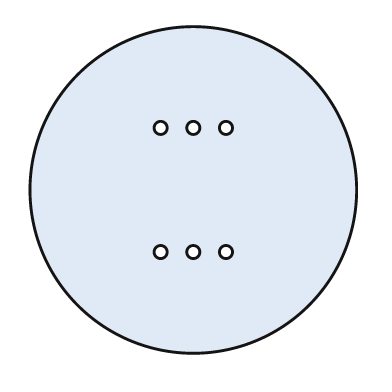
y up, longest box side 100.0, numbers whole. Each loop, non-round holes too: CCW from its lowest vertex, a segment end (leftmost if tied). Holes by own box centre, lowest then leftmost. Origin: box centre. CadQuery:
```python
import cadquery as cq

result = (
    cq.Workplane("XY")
    .moveTo(0.0, 0.0)
    .circle(50.0)
    .moveTo(-10.0, -19.0)
    .circle(2.0)
    .moveTo(0.0, -19.0)
    .circle(2.0)
    .moveTo(10.0, -19.0)
    .circle(2.0)
    .moveTo(-10.0, 19.0)
    .circle(2.0)
    .moveTo(0.0, 19.0)
    .circle(2.0)
    .moveTo(10.0, 19.0)
    .circle(2.0)
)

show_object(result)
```